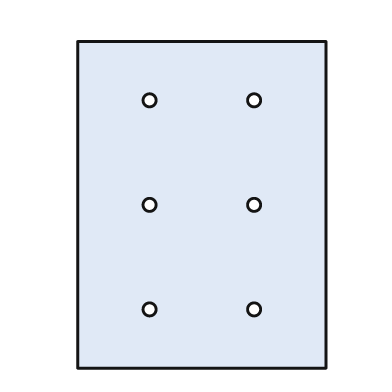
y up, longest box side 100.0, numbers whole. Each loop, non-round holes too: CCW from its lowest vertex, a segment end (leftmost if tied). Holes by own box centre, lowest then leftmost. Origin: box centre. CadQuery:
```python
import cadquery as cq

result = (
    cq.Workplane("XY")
    .moveTo(-38.0, -50.0)
    .lineTo(38.0, -50.0)
    .lineTo(38.0, 50.0)
    .lineTo(-38.0, 50.0)
    .close()
    .moveTo(-16.0, -32.0)
    .circle(2.0)
    .moveTo(16.0, -32.0)
    .circle(2.0)
    .moveTo(-16.0, 0.0)
    .circle(2.0)
    .moveTo(16.0, 0.0)
    .circle(2.0)
    .moveTo(-16.0, 32.0)
    .circle(2.0)
    .moveTo(16.0, 32.0)
    .circle(2.0)
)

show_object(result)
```